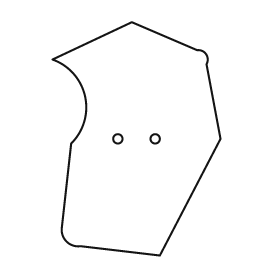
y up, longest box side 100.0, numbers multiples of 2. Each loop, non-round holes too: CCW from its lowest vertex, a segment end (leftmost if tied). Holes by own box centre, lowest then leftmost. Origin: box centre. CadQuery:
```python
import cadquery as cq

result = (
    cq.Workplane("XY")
    .moveTo(10.0, -50.0)
    .lineTo(36.0, 0.0)
    .lineTo(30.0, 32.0)
    .threePointArc((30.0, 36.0), (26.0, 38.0))
    .lineTo(-2.0, 50.0)
    .lineTo(-36.0, 34.0)
    .threePointArc((-22.0, 18.0), (-28.0, -2.0))
    .lineTo(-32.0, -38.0)
    .threePointArc((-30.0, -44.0), (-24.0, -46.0))
    .close()
    .moveTo(-8.0, 0.0)
    .circle(2.0)
    .moveTo(8.0, 0.0)
    .circle(2.0)
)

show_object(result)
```